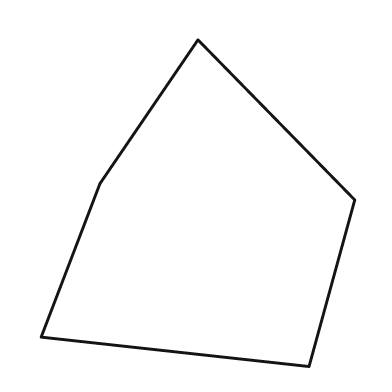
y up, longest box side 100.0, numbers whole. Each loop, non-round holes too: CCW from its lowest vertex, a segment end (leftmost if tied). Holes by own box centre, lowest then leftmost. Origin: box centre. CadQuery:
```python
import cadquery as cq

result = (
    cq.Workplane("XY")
    .moveTo(34.0, -50.0)
    .lineTo(48.0, 1.0)
    .lineTo(0.0, 50.0)
    .lineTo(-30.0, 6.0)
    .lineTo(-48.0, -41.0)
    .close()
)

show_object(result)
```